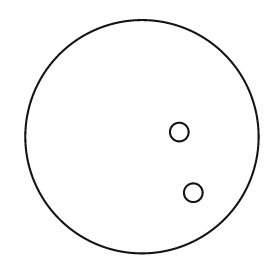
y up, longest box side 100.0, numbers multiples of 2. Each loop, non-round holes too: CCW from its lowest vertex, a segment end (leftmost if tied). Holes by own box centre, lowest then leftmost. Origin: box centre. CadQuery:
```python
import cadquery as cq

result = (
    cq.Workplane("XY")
    .moveTo(0.0, 0.0)
    .circle(50.0)
    .moveTo(22.0, -24.0)
    .circle(4.0)
    .moveTo(16.0, 2.0)
    .circle(4.0)
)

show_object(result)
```